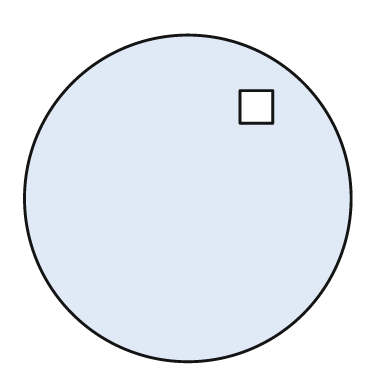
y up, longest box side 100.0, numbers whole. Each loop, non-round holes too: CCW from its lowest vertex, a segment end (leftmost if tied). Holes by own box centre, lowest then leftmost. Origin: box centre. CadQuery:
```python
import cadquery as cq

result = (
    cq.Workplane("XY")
    .moveTo(0.0, 0.0)
    .circle(50.0)
    .moveTo(16.0, 23.0)
    .lineTo(26.0, 23.0)
    .lineTo(26.0, 33.0)
    .lineTo(16.0, 33.0)
    .close()
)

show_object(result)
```